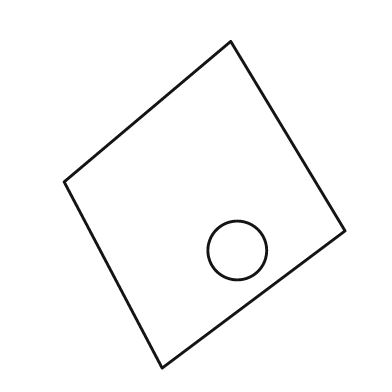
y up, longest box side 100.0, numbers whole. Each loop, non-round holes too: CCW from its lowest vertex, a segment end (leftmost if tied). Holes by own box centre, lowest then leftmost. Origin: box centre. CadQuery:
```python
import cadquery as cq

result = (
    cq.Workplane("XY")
    .moveTo(-13.0, -50.0)
    .lineTo(43.0, -8.0)
    .lineTo(8.0, 50.0)
    .lineTo(-43.0, 7.0)
    .close()
    .moveTo(10.0, -14.0)
    .circle(9.0)
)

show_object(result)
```